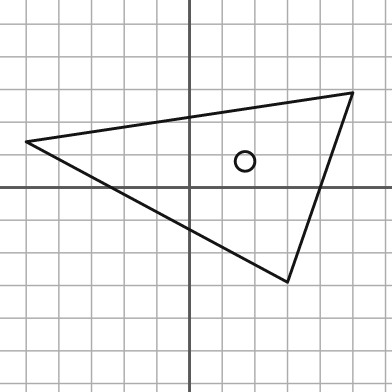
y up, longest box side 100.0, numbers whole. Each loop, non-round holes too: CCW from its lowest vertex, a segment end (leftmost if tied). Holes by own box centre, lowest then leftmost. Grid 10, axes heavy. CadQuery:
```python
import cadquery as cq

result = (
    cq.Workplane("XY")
    .moveTo(30.0, -29.0)
    .lineTo(50.0, 29.0)
    .lineTo(-50.0, 14.0)
    .close()
    .moveTo(17.0, 8.0)
    .circle(3.0)
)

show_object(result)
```